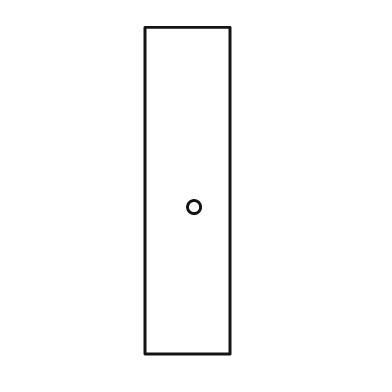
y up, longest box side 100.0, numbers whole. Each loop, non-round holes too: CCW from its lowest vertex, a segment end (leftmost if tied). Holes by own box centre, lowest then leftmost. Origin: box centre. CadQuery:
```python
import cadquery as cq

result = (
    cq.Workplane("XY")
    .moveTo(-13.0, -50.0)
    .lineTo(13.0, -50.0)
    .lineTo(13.0, 50.0)
    .lineTo(-13.0, 50.0)
    .close()
    .moveTo(2.0, -5.0)
    .circle(2.0)
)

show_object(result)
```